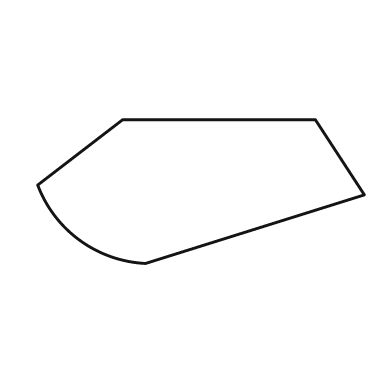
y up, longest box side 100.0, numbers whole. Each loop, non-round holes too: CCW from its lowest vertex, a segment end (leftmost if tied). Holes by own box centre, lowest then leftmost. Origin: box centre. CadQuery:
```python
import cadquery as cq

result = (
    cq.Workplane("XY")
    .moveTo(-17.0, -22.0)
    .lineTo(50.0, -1.0)
    .lineTo(35.0, 22.0)
    .lineTo(-24.0, 22.0)
    .lineTo(-50.0, 2.0)
    .threePointArc((-37.0, -15.0), (-17.0, -22.0))
    .close()
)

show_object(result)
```